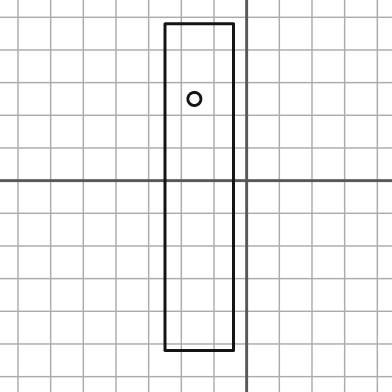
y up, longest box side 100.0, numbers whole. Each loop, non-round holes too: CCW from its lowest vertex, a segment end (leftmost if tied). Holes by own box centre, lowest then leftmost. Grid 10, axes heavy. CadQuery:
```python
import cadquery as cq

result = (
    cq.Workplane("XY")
    .moveTo(-25.0, -52.0)
    .lineTo(-4.0, -52.0)
    .lineTo(-4.0, 48.0)
    .lineTo(-25.0, 48.0)
    .close()
    .moveTo(-16.0, 25.0)
    .circle(2.0)
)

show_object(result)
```